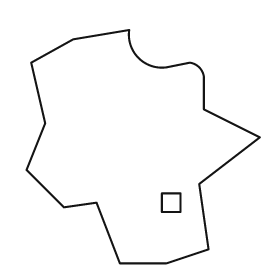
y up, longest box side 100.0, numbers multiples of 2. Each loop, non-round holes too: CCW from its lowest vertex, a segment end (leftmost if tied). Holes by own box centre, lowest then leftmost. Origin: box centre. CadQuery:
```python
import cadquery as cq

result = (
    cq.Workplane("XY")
    .moveTo(-10.0, -50.0)
    .lineTo(10.0, -50.0)
    .lineTo(28.0, -44.0)
    .lineTo(24.0, -16.0)
    .lineTo(50.0, 4.0)
    .lineTo(26.0, 16.0)
    .lineTo(26.0, 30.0)
    .threePointArc((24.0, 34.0), (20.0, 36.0))
    .lineTo(10.0, 34.0)
    .threePointArc((-2.0, 38.0), (-6.0, 50.0))
    .lineTo(-30.0, 46.0)
    .lineTo(-48.0, 36.0)
    .lineTo(-42.0, 10.0)
    .lineTo(-50.0, -10.0)
    .lineTo(-34.0, -26.0)
    .lineTo(-20.0, -24.0)
    .close()
    .moveTo(8.0, -28.0)
    .lineTo(16.0, -28.0)
    .lineTo(16.0, -20.0)
    .lineTo(8.0, -20.0)
    .close()
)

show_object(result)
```